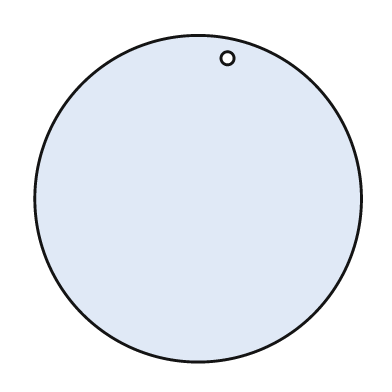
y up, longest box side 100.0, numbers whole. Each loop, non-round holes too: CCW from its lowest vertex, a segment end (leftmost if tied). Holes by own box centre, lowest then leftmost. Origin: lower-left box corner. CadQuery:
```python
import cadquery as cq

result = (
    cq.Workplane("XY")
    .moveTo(50.0, 50.0)
    .circle(50.0)
    .moveTo(59.0, 93.0)
    .circle(2.0)
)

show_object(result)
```